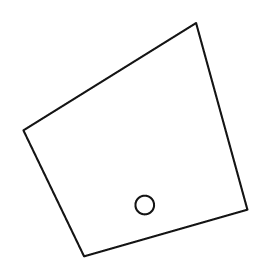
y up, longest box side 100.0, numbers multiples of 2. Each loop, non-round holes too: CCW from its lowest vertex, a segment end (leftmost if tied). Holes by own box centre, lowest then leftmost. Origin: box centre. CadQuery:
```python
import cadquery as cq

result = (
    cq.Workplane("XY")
    .moveTo(-22.0, -50.0)
    .lineTo(48.0, -30.0)
    .lineTo(26.0, 50.0)
    .lineTo(-48.0, 4.0)
    .close()
    .moveTo(4.0, -28.0)
    .circle(4.0)
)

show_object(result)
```